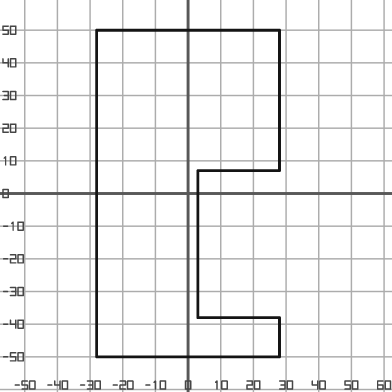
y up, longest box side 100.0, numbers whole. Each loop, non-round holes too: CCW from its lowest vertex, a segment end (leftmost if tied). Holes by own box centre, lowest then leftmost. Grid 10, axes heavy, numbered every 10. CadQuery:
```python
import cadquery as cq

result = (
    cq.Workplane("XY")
    .moveTo(-28.0, -50.0)
    .lineTo(28.0, -50.0)
    .lineTo(28.0, -38.0)
    .lineTo(3.0, -38.0)
    .lineTo(3.0, 7.0)
    .lineTo(28.0, 7.0)
    .lineTo(28.0, 50.0)
    .lineTo(-28.0, 50.0)
    .close()
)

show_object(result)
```